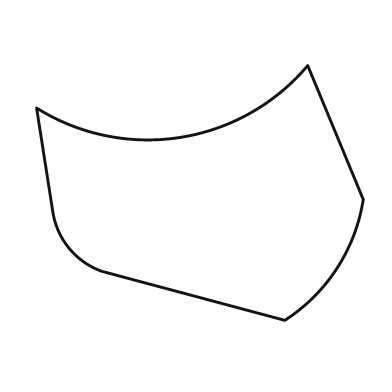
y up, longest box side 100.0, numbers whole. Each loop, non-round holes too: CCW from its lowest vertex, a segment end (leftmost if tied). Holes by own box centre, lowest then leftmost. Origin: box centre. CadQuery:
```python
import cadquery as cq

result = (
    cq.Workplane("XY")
    .moveTo(26.0, -39.0)
    .threePointArc((42.0, -23.0), (50.0, -2.0))
    .lineTo(33.0, 39.0)
    .threePointArc((-6.0, 17.0), (-50.0, 26.0))
    .lineTo(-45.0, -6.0)
    .threePointArc((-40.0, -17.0), (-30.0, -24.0))
    .close()
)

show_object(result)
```